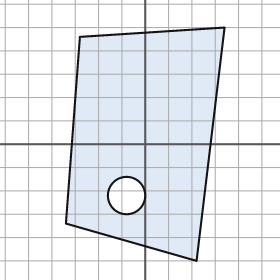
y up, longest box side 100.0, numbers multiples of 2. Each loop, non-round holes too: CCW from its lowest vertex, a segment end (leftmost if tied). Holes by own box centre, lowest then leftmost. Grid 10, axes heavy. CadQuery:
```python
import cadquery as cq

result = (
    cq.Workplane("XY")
    .moveTo(22.0, -50.0)
    .lineTo(34.0, 50.0)
    .lineTo(-28.0, 46.0)
    .lineTo(-34.0, -34.0)
    .close()
    .moveTo(-8.0, -22.0)
    .circle(8.0)
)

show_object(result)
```